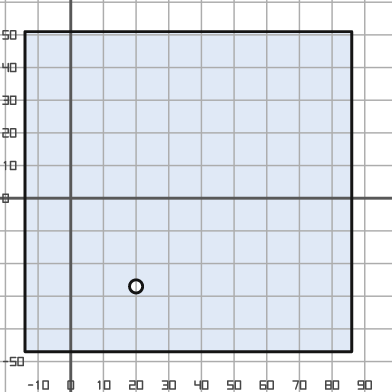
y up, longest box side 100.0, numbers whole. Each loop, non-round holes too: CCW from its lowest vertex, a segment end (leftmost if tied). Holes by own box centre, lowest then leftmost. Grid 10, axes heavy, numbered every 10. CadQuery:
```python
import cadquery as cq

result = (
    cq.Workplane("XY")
    .moveTo(-14.0, -47.0)
    .lineTo(86.0, -47.0)
    .lineTo(86.0, 51.0)
    .lineTo(-14.0, 51.0)
    .close()
    .moveTo(20.0, -27.0)
    .circle(2.0)
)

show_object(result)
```